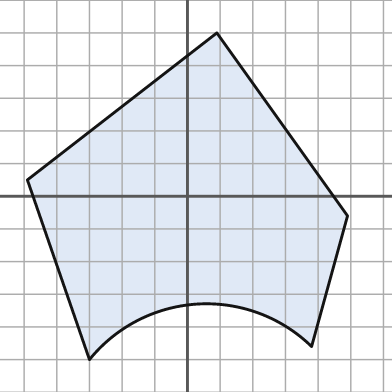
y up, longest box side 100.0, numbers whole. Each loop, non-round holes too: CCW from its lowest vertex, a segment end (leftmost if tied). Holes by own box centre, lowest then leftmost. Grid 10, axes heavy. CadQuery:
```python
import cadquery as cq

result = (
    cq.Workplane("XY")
    .moveTo(-30.0, -50.0)
    .threePointArc((3.0, -33.0), (38.0, -46.0))
    .lineTo(49.0, -6.0)
    .lineTo(9.0, 50.0)
    .lineTo(-49.0, 5.0)
    .close()
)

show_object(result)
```